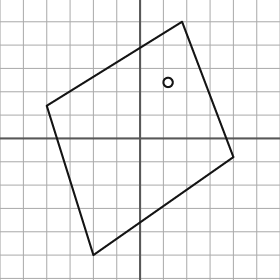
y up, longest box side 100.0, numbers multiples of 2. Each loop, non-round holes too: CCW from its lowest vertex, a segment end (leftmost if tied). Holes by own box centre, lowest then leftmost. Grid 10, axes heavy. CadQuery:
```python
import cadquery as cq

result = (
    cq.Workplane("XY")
    .moveTo(-20.0, -50.0)
    .lineTo(40.0, -8.0)
    .lineTo(18.0, 50.0)
    .lineTo(-40.0, 14.0)
    .close()
    .moveTo(12.0, 24.0)
    .circle(2.0)
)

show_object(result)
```